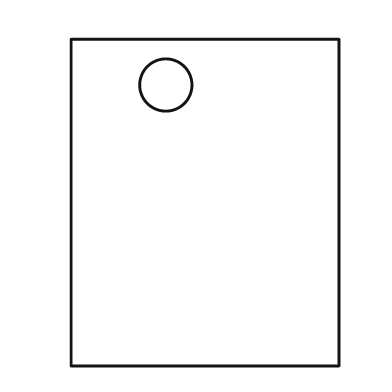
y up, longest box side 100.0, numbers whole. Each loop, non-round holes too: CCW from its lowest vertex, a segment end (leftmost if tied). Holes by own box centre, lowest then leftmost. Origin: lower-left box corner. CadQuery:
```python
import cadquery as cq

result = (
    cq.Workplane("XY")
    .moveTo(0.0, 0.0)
    .lineTo(82.0, 0.0)
    .lineTo(82.0, 100.0)
    .lineTo(0.0, 100.0)
    .close()
    .moveTo(29.0, 86.0)
    .circle(8.0)
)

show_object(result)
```